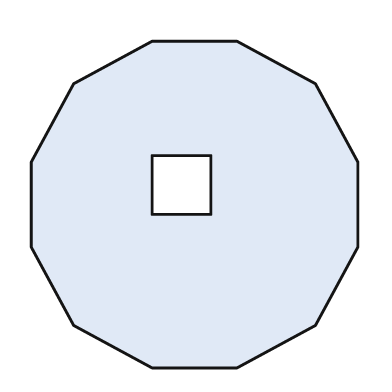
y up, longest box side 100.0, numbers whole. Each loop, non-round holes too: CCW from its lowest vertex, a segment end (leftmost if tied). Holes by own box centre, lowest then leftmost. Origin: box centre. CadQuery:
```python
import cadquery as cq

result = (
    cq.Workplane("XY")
    .moveTo(-13.0, -50.0)
    .lineTo(13.0, -50.0)
    .lineTo(37.0, -37.0)
    .lineTo(50.0, -13.0)
    .lineTo(50.0, 13.0)
    .lineTo(37.0, 37.0)
    .lineTo(13.0, 50.0)
    .lineTo(-13.0, 50.0)
    .lineTo(-37.0, 37.0)
    .lineTo(-50.0, 13.0)
    .lineTo(-50.0, -13.0)
    .lineTo(-37.0, -37.0)
    .close()
    .moveTo(-13.0, -3.0)
    .lineTo(5.0, -3.0)
    .lineTo(5.0, 15.0)
    .lineTo(-13.0, 15.0)
    .close()
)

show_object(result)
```